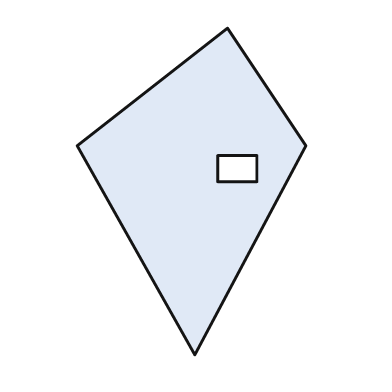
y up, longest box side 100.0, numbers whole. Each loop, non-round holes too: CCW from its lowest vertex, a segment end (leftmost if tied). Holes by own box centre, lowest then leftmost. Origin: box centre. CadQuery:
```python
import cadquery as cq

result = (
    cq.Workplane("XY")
    .moveTo(1.0, -50.0)
    .lineTo(35.0, 14.0)
    .lineTo(11.0, 50.0)
    .lineTo(-35.0, 14.0)
    .close()
    .moveTo(8.0, 3.0)
    .lineTo(20.0, 3.0)
    .lineTo(20.0, 11.0)
    .lineTo(8.0, 11.0)
    .close()
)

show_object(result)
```